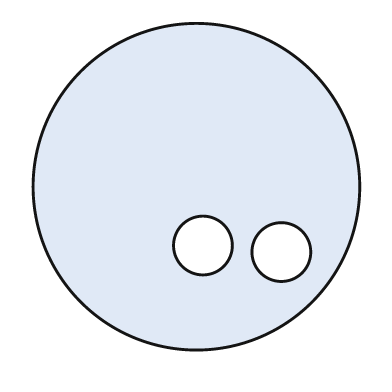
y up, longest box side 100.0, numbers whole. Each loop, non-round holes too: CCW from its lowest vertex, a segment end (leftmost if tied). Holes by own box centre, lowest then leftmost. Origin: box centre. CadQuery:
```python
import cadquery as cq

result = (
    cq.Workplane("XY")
    .moveTo(0.0, 0.0)
    .circle(50.0)
    .moveTo(26.0, -20.0)
    .circle(9.0)
    .moveTo(2.0, -18.0)
    .circle(9.0)
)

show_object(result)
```